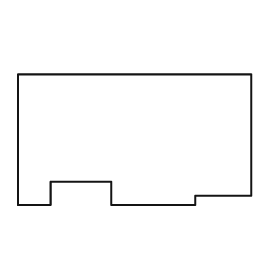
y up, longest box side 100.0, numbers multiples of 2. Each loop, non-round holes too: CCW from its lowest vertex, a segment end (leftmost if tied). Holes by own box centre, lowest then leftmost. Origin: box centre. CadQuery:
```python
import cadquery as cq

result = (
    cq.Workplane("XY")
    .moveTo(-50.0, -28.0)
    .lineTo(-36.0, -28.0)
    .lineTo(-36.0, -18.0)
    .lineTo(-10.0, -18.0)
    .lineTo(-10.0, -28.0)
    .lineTo(26.0, -28.0)
    .lineTo(26.0, -24.0)
    .lineTo(50.0, -24.0)
    .lineTo(50.0, 28.0)
    .lineTo(-50.0, 28.0)
    .close()
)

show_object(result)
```